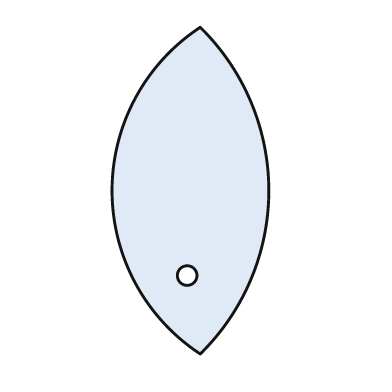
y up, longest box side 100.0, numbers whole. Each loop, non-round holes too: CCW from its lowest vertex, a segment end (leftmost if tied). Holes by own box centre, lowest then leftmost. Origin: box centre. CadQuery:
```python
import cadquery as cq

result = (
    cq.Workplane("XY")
    .moveTo(3.0, -50.0)
    .threePointArc((24.0, 0.0), (3.0, 50.0))
    .threePointArc((-24.0, 0.0), (3.0, -50.0))
    .close()
    .moveTo(-1.0, -26.0)
    .circle(3.0)
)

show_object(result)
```